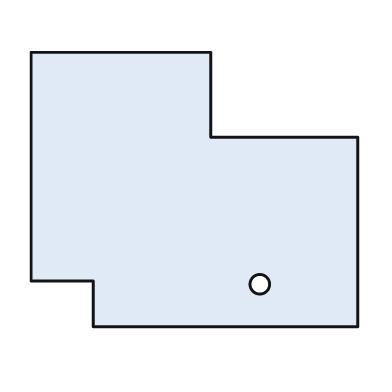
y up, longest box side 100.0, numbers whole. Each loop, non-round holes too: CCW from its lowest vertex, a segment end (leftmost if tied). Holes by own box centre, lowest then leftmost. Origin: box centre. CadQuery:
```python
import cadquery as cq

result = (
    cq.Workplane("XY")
    .moveTo(-31.0, -42.0)
    .lineTo(50.0, -42.0)
    .lineTo(50.0, 16.0)
    .lineTo(5.0, 16.0)
    .lineTo(5.0, 42.0)
    .lineTo(-50.0, 42.0)
    .lineTo(-50.0, -28.0)
    .lineTo(-31.0, -28.0)
    .close()
    .moveTo(20.0, -29.0)
    .circle(3.0)
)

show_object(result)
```